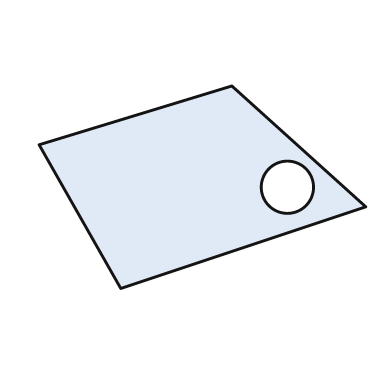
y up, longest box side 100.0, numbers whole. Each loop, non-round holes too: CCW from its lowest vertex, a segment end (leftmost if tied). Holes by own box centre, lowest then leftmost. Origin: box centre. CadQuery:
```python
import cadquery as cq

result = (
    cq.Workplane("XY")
    .moveTo(-25.0, -31.0)
    .lineTo(50.0, -6.0)
    .lineTo(9.0, 31.0)
    .lineTo(-50.0, 13.0)
    .close()
    .moveTo(26.0, 0.0)
    .circle(8.0)
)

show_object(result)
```